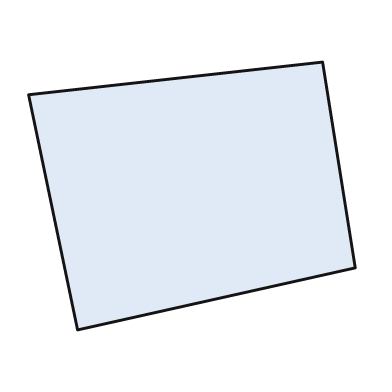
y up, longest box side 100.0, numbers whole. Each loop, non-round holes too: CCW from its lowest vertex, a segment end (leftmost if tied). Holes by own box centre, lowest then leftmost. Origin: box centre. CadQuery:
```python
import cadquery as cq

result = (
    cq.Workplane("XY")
    .moveTo(-35.0, -41.0)
    .lineTo(50.0, -22.0)
    .lineTo(40.0, 41.0)
    .lineTo(-50.0, 31.0)
    .close()
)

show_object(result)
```